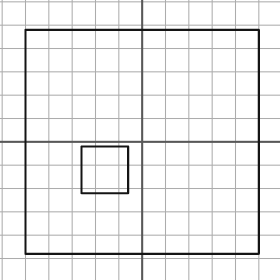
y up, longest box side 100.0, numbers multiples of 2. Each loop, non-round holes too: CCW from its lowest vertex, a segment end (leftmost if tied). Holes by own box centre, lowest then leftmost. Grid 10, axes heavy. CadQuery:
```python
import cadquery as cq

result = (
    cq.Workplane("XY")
    .moveTo(-50.0, -48.0)
    .lineTo(50.0, -48.0)
    .lineTo(50.0, 48.0)
    .lineTo(-50.0, 48.0)
    .close()
    .moveTo(-26.0, -22.0)
    .lineTo(-6.0, -22.0)
    .lineTo(-6.0, -2.0)
    .lineTo(-26.0, -2.0)
    .close()
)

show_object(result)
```